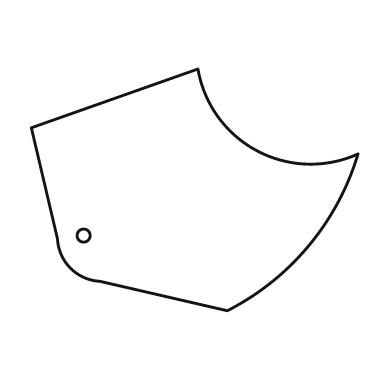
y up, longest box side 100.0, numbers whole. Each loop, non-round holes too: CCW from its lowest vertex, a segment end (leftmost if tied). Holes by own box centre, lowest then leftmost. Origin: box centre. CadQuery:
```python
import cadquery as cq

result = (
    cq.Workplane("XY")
    .moveTo(10.0, -37.0)
    .threePointArc((35.0, -17.0), (50.0, 11.0))
    .threePointArc((19.0, 12.0), (1.0, 37.0))
    .lineTo(-50.0, 19.0)
    .lineTo(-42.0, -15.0)
    .threePointArc((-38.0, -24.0), (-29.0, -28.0))
    .close()
    .moveTo(-34.0, -14.0)
    .circle(2.0)
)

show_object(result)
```